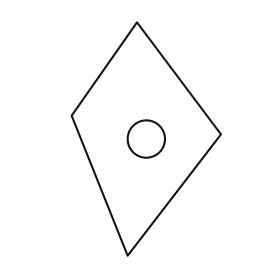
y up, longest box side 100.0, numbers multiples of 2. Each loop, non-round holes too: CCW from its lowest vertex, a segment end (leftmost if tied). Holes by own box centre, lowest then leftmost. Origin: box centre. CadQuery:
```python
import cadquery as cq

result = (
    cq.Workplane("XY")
    .moveTo(-8.0, -50.0)
    .lineTo(32.0, 2.0)
    .lineTo(-4.0, 50.0)
    .lineTo(-32.0, 10.0)
    .close()
    .moveTo(0.0, 0.0)
    .circle(8.0)
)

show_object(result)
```